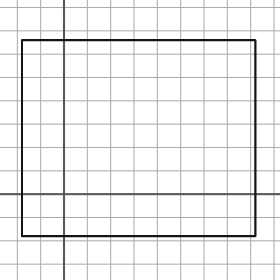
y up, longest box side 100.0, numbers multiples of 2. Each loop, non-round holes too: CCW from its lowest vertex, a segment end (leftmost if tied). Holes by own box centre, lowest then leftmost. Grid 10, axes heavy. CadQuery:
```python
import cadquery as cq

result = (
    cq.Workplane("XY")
    .moveTo(-18.0, -18.0)
    .lineTo(82.0, -18.0)
    .lineTo(82.0, 66.0)
    .lineTo(-18.0, 66.0)
    .close()
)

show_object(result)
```